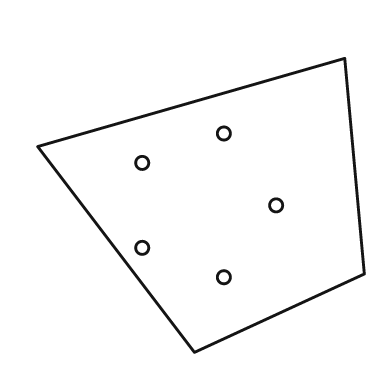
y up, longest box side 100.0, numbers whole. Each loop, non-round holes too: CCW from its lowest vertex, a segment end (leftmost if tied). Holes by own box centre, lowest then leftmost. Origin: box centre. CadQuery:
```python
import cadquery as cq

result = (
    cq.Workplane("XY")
    .moveTo(-2.0, -45.0)
    .lineTo(50.0, -21.0)
    .lineTo(44.0, 45.0)
    .lineTo(-50.0, 18.0)
    .close()
    .moveTo(7.0, -22.0)
    .circle(2.0)
    .moveTo(-18.0, -13.0)
    .circle(2.0)
    .moveTo(23.0, 0.0)
    .circle(2.0)
    .moveTo(-18.0, 13.0)
    .circle(2.0)
    .moveTo(7.0, 22.0)
    .circle(2.0)
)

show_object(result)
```